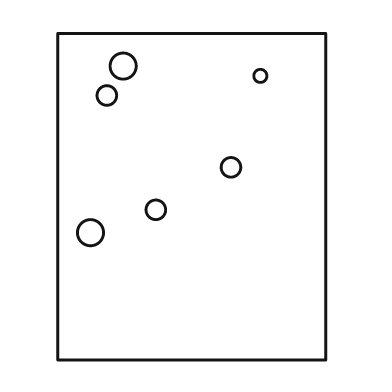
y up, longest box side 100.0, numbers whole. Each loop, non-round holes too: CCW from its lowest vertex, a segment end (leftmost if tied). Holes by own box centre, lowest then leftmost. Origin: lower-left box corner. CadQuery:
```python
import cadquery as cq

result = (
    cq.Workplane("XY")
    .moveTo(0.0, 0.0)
    .lineTo(82.0, 0.0)
    .lineTo(82.0, 100.0)
    .lineTo(0.0, 100.0)
    .close()
    .moveTo(10.0, 39.0)
    .circle(4.0)
    .moveTo(30.0, 46.0)
    .circle(3.0)
    .moveTo(53.0, 59.0)
    .circle(3.0)
    .moveTo(15.0, 81.0)
    .circle(3.0)
    .moveTo(62.0, 87.0)
    .circle(2.0)
    .moveTo(20.0, 90.0)
    .circle(4.0)
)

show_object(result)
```